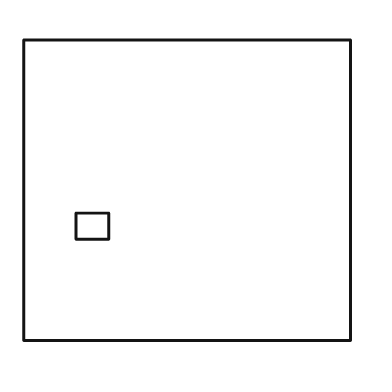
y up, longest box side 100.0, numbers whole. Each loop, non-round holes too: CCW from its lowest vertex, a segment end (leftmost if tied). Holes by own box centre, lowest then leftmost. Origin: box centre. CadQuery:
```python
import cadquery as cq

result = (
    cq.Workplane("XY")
    .moveTo(-50.0, -46.0)
    .lineTo(50.0, -46.0)
    .lineTo(50.0, 46.0)
    .lineTo(-50.0, 46.0)
    .close()
    .moveTo(-34.0, -15.0)
    .lineTo(-24.0, -15.0)
    .lineTo(-24.0, -7.0)
    .lineTo(-34.0, -7.0)
    .close()
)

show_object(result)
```